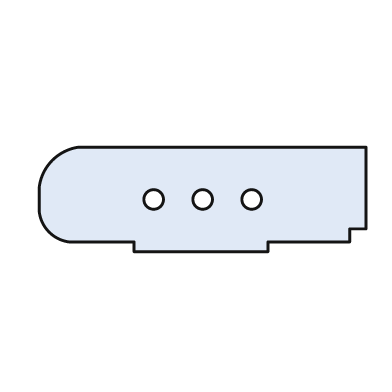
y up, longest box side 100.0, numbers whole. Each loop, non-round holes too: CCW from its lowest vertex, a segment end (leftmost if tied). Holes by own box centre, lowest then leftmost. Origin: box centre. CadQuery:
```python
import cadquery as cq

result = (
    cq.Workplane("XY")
    .moveTo(-21.0, -16.0)
    .lineTo(20.0, -16.0)
    .lineTo(20.0, -13.0)
    .lineTo(45.0, -13.0)
    .lineTo(45.0, -9.0)
    .lineTo(50.0, -9.0)
    .lineTo(50.0, 16.0)
    .lineTo(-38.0, 16.0)
    .threePointArc((-46.0, 12.0), (-50.0, 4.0))
    .lineTo(-50.0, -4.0)
    .threePointArc((-47.0, -10.0), (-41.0, -13.0))
    .lineTo(-21.0, -13.0)
    .close()
    .moveTo(-15.0, 0.0)
    .circle(3.0)
    .moveTo(0.0, 0.0)
    .circle(3.0)
    .moveTo(15.0, 0.0)
    .circle(3.0)
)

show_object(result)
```